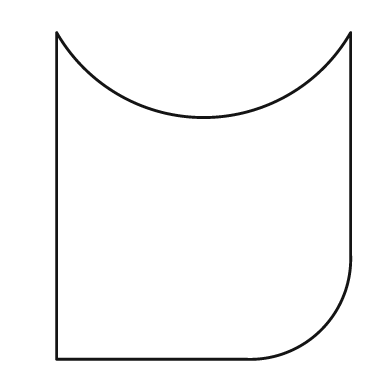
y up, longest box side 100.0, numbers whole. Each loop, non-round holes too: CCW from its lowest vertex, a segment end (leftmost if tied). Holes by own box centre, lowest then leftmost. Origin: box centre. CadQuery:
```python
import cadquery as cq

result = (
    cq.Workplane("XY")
    .moveTo(-45.0, -50.0)
    .lineTo(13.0, -50.0)
    .threePointArc((36.0, -41.0), (45.0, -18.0))
    .lineTo(45.0, 50.0)
    .threePointArc((0.0, 24.0), (-45.0, 50.0))
    .close()
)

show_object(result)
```